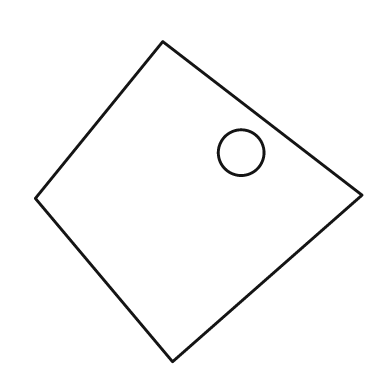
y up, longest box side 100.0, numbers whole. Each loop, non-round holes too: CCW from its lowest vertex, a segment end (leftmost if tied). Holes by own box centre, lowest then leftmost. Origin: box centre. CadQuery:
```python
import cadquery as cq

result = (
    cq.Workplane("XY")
    .moveTo(-8.0, -49.0)
    .lineTo(50.0, 2.0)
    .lineTo(-11.0, 49.0)
    .lineTo(-50.0, 1.0)
    .close()
    .moveTo(13.0, 15.0)
    .circle(7.0)
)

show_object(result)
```